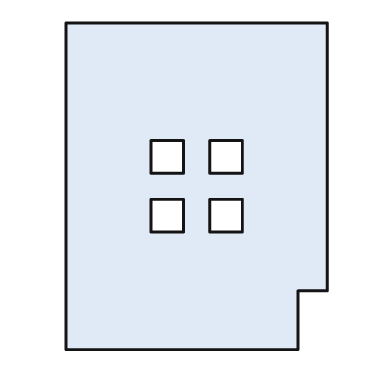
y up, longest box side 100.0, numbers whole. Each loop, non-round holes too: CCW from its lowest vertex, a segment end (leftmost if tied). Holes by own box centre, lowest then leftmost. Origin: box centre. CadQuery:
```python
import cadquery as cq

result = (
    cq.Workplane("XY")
    .moveTo(-40.0, -50.0)
    .lineTo(31.0, -50.0)
    .lineTo(31.0, -32.0)
    .lineTo(40.0, -32.0)
    .lineTo(40.0, 50.0)
    .lineTo(-40.0, 50.0)
    .close()
    .moveTo(-14.0, -14.0)
    .lineTo(-4.0, -14.0)
    .lineTo(-4.0, -4.0)
    .lineTo(-14.0, -4.0)
    .close()
    .moveTo(4.0, -14.0)
    .lineTo(14.0, -14.0)
    .lineTo(14.0, -4.0)
    .lineTo(4.0, -4.0)
    .close()
    .moveTo(-14.0, 4.0)
    .lineTo(-4.0, 4.0)
    .lineTo(-4.0, 14.0)
    .lineTo(-14.0, 14.0)
    .close()
    .moveTo(4.0, 4.0)
    .lineTo(14.0, 4.0)
    .lineTo(14.0, 14.0)
    .lineTo(4.0, 14.0)
    .close()
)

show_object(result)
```